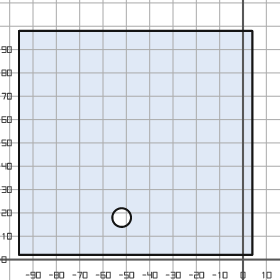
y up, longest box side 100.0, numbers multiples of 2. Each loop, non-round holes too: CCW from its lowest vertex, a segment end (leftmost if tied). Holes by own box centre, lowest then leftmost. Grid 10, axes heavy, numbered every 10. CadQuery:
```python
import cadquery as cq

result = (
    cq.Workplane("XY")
    .moveTo(-96.0, 2.0)
    .lineTo(4.0, 2.0)
    .lineTo(4.0, 98.0)
    .lineTo(-96.0, 98.0)
    .close()
    .moveTo(-52.0, 18.0)
    .circle(4.0)
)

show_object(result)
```